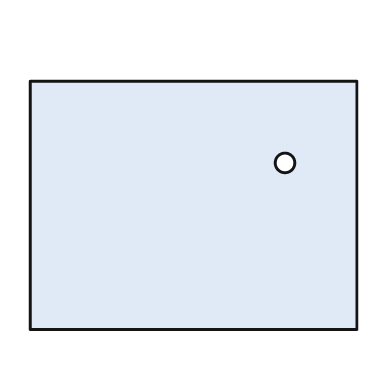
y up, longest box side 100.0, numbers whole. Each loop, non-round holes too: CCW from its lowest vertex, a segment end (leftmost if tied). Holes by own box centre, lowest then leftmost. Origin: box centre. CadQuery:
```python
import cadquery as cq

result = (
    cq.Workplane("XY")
    .moveTo(-50.0, -38.0)
    .lineTo(50.0, -38.0)
    .lineTo(50.0, 38.0)
    .lineTo(-50.0, 38.0)
    .close()
    .moveTo(28.0, 13.0)
    .circle(3.0)
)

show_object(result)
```